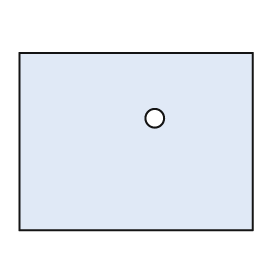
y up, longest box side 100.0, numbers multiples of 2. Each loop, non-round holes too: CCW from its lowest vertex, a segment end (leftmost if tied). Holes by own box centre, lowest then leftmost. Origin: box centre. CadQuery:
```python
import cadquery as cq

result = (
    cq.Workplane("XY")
    .moveTo(-50.0, -38.0)
    .lineTo(50.0, -38.0)
    .lineTo(50.0, 38.0)
    .lineTo(-50.0, 38.0)
    .close()
    .moveTo(8.0, 10.0)
    .circle(4.0)
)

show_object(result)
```